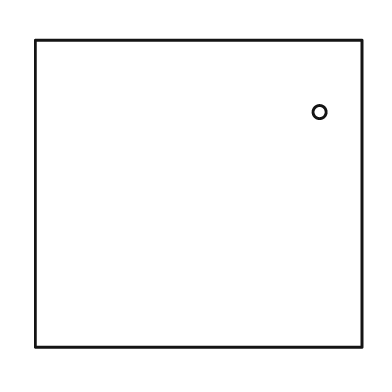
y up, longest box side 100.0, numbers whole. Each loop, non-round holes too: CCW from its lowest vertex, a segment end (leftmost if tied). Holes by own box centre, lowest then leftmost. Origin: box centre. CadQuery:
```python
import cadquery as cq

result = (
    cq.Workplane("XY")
    .moveTo(-50.0, -47.0)
    .lineTo(50.0, -47.0)
    .lineTo(50.0, 47.0)
    .lineTo(-50.0, 47.0)
    .close()
    .moveTo(37.0, 25.0)
    .circle(2.0)
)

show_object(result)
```